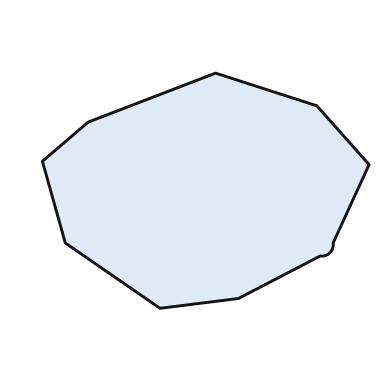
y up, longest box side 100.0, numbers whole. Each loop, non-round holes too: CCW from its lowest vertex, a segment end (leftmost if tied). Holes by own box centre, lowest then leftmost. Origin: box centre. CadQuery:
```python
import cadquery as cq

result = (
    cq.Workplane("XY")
    .moveTo(-14.0, -36.0)
    .lineTo(10.0, -33.0)
    .lineTo(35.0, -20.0)
    .threePointArc((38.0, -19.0), (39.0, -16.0))
    .lineTo(50.0, 8.0)
    .lineTo(34.0, 26.0)
    .lineTo(3.0, 36.0)
    .lineTo(-36.0, 21.0)
    .lineTo(-50.0, 9.0)
    .lineTo(-43.0, -16.0)
    .close()
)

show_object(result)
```